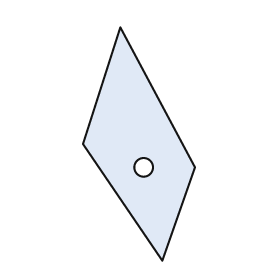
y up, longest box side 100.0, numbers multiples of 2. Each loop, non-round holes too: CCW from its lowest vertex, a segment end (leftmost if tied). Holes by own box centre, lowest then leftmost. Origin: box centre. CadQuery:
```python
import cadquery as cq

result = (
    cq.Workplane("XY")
    .moveTo(10.0, -50.0)
    .lineTo(24.0, -10.0)
    .lineTo(-8.0, 50.0)
    .lineTo(-24.0, 0.0)
    .close()
    .moveTo(2.0, -10.0)
    .circle(4.0)
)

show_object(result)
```